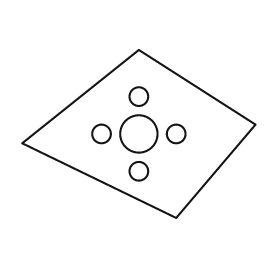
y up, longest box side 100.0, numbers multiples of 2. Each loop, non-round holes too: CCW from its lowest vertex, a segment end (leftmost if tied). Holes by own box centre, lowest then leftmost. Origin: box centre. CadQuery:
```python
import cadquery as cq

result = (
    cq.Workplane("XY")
    .moveTo(16.0, -36.0)
    .lineTo(50.0, 4.0)
    .lineTo(0.0, 36.0)
    .lineTo(-50.0, -4.0)
    .close()
    .moveTo(0.0, -16.0)
    .circle(4.0)
    .moveTo(-16.0, 0.0)
    .circle(4.0)
    .moveTo(0.0, 0.0)
    .circle(8.0)
    .moveTo(16.0, 0.0)
    .circle(4.0)
    .moveTo(0.0, 16.0)
    .circle(4.0)
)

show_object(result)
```